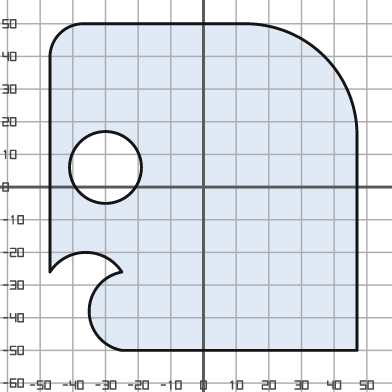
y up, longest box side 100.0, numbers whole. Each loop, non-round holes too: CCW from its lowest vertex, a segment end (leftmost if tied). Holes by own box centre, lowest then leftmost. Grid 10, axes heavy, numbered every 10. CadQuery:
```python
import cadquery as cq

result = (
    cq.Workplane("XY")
    .moveTo(-25.0, -50.0)
    .lineTo(47.0, -50.0)
    .lineTo(47.0, 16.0)
    .threePointArc((37.0, 40.0), (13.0, 50.0))
    .lineTo(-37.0, 50.0)
    .threePointArc((-44.0, 47.0), (-47.0, 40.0))
    .lineTo(-47.0, -26.0)
    .threePointArc((-36.0, -20.0), (-25.0, -26.0))
    .threePointArc((-35.0, -38.0), (-25.0, -50.0))
    .close()
    .moveTo(-30.0, 6.0)
    .circle(11.0)
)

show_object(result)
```